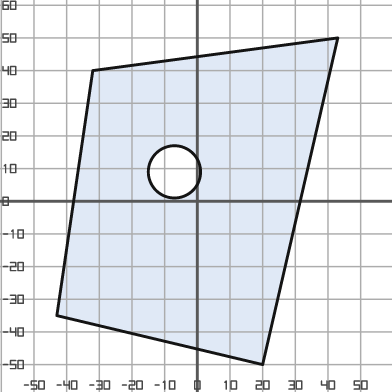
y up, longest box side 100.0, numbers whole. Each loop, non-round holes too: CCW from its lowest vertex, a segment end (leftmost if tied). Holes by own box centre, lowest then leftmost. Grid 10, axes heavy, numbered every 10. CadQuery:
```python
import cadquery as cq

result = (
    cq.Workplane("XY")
    .moveTo(20.0, -50.0)
    .lineTo(43.0, 50.0)
    .lineTo(-32.0, 40.0)
    .lineTo(-43.0, -35.0)
    .close()
    .moveTo(-7.0, 9.0)
    .circle(8.0)
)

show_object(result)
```